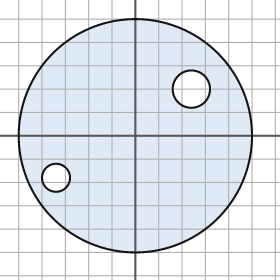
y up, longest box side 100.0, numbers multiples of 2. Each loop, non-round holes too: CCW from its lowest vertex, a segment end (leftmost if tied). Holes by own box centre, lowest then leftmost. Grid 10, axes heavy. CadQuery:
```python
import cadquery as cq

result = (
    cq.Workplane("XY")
    .moveTo(0.0, 0.0)
    .circle(50.0)
    .moveTo(-34.0, -18.0)
    .circle(6.0)
    .moveTo(24.0, 20.0)
    .circle(8.0)
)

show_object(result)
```